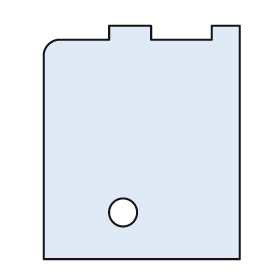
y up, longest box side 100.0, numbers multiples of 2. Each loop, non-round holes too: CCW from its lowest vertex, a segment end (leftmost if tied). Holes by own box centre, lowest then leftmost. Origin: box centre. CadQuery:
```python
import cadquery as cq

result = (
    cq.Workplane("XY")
    .moveTo(-42.0, -50.0)
    .lineTo(42.0, -50.0)
    .lineTo(42.0, 50.0)
    .lineTo(30.0, 50.0)
    .lineTo(30.0, 44.0)
    .lineTo(4.0, 44.0)
    .lineTo(4.0, 50.0)
    .lineTo(-14.0, 50.0)
    .lineTo(-14.0, 44.0)
    .lineTo(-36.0, 44.0)
    .threePointArc((-40.0, 42.0), (-42.0, 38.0))
    .close()
    .moveTo(-8.0, -30.0)
    .circle(6.0)
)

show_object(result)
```